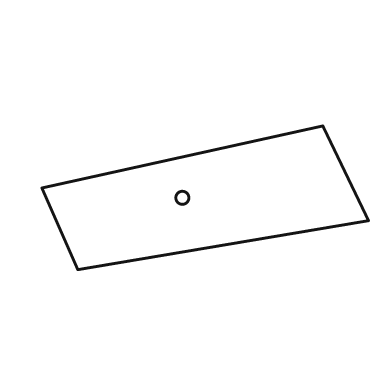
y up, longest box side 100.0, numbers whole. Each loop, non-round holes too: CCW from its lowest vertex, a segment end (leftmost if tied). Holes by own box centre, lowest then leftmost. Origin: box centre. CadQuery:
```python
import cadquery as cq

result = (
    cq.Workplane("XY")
    .moveTo(-39.0, -22.0)
    .lineTo(50.0, -7.0)
    .lineTo(36.0, 22.0)
    .lineTo(-50.0, 3.0)
    .close()
    .moveTo(-7.0, 0.0)
    .circle(2.0)
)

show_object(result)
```